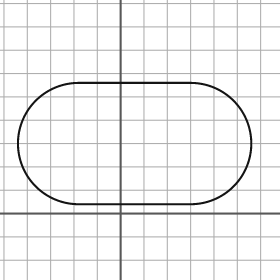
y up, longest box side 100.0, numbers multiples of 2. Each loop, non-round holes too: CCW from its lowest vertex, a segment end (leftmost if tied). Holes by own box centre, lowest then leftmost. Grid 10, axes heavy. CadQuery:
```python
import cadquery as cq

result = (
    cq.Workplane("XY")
    .moveTo(-18.0, 4.0)
    .lineTo(30.0, 4.0)
    .threePointArc((56.0, 30.0), (30.0, 56.0))
    .lineTo(-18.0, 56.0)
    .threePointArc((-44.0, 30.0), (-18.0, 4.0))
    .close()
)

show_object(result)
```